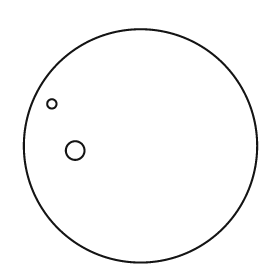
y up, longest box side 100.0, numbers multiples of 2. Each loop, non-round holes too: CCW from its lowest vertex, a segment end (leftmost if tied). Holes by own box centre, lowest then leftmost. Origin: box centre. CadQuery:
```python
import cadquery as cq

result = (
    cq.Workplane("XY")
    .moveTo(0.0, 0.0)
    .circle(50.0)
    .moveTo(-28.0, -2.0)
    .circle(4.0)
    .moveTo(-38.0, 18.0)
    .circle(2.0)
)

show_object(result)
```